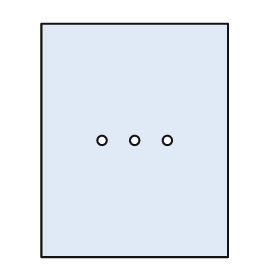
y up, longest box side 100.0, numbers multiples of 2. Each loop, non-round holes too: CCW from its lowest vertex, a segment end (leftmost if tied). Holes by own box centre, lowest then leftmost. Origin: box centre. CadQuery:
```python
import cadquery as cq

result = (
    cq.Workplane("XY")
    .moveTo(-40.0, -50.0)
    .lineTo(40.0, -50.0)
    .lineTo(40.0, 50.0)
    .lineTo(-40.0, 50.0)
    .close()
    .moveTo(-14.0, 0.0)
    .circle(2.0)
    .moveTo(0.0, 0.0)
    .circle(2.0)
    .moveTo(14.0, 0.0)
    .circle(2.0)
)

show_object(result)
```